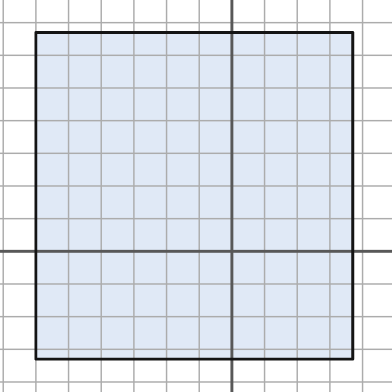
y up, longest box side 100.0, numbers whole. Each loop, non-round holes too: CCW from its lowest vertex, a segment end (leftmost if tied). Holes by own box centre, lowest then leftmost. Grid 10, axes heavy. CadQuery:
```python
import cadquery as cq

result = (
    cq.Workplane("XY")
    .moveTo(-60.0, -33.0)
    .lineTo(37.0, -33.0)
    .lineTo(37.0, 67.0)
    .lineTo(-60.0, 67.0)
    .close()
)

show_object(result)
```